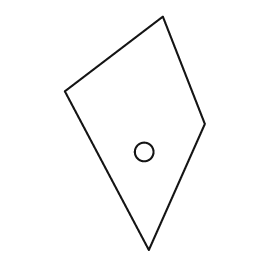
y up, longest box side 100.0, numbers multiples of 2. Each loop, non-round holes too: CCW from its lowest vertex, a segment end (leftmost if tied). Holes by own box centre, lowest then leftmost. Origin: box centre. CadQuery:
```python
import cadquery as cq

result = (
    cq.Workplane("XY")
    .moveTo(6.0, -50.0)
    .lineTo(30.0, 4.0)
    .lineTo(12.0, 50.0)
    .lineTo(-30.0, 18.0)
    .close()
    .moveTo(4.0, -8.0)
    .circle(4.0)
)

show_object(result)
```